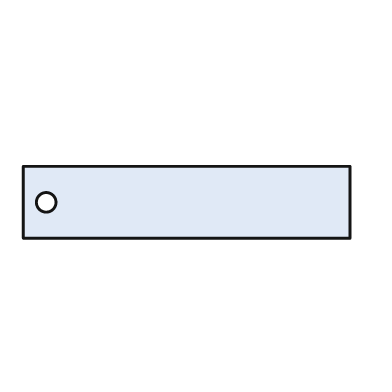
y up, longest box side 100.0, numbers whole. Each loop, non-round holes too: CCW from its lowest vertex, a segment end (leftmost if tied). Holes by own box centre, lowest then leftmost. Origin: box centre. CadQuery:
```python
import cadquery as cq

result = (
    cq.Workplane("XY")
    .moveTo(-50.0, -11.0)
    .lineTo(50.0, -11.0)
    .lineTo(50.0, 11.0)
    .lineTo(-50.0, 11.0)
    .close()
    .moveTo(-43.0, 0.0)
    .circle(3.0)
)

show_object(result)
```